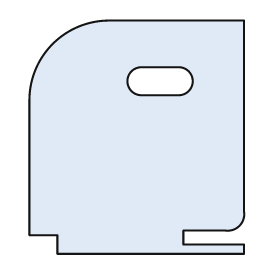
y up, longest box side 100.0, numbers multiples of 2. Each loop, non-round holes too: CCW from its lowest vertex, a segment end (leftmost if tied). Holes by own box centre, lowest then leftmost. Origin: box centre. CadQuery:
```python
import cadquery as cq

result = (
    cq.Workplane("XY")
    .moveTo(-34.0, -50.0)
    .lineTo(46.0, -50.0)
    .lineTo(46.0, -46.0)
    .lineTo(20.0, -46.0)
    .lineTo(20.0, -40.0)
    .lineTo(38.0, -40.0)
    .threePointArc((44.0, -38.0), (46.0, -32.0))
    .lineTo(46.0, 50.0)
    .lineTo(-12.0, 50.0)
    .threePointArc((-36.0, 40.0), (-46.0, 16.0))
    .lineTo(-46.0, -42.0)
    .lineTo(-34.0, -42.0)
    .close()
    .moveTo(2.0, 18.0)
    .lineTo(18.0, 18.0)
    .threePointArc((24.0, 24.0), (18.0, 30.0))
    .lineTo(2.0, 30.0)
    .threePointArc((-4.0, 24.0), (2.0, 18.0))
    .close()
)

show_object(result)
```